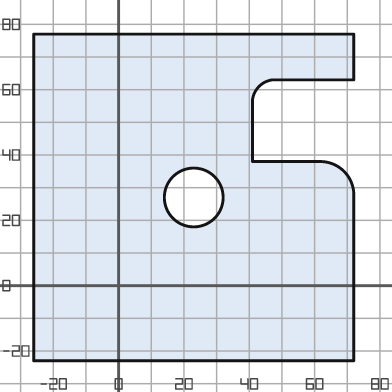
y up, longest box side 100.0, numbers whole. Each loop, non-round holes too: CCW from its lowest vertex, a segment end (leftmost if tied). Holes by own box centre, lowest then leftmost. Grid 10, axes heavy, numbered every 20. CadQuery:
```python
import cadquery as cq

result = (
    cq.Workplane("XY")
    .moveTo(-26.0, -23.0)
    .lineTo(72.0, -23.0)
    .lineTo(72.0, 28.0)
    .threePointArc((69.0, 35.0), (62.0, 38.0))
    .lineTo(41.0, 38.0)
    .lineTo(41.0, 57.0)
    .threePointArc((43.0, 61.0), (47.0, 63.0))
    .lineTo(72.0, 63.0)
    .lineTo(72.0, 77.0)
    .lineTo(-26.0, 77.0)
    .close()
    .moveTo(23.0, 27.0)
    .circle(9.0)
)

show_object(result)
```